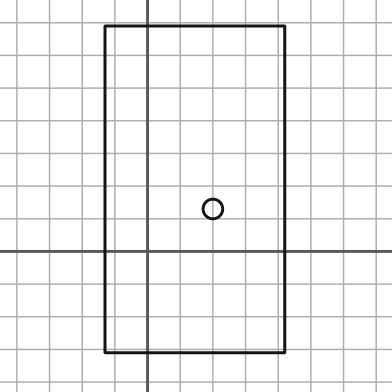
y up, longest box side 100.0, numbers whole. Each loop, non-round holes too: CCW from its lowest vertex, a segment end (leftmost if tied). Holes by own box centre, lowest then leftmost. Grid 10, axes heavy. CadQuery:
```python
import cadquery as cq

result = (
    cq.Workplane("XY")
    .moveTo(-13.0, -31.0)
    .lineTo(42.0, -31.0)
    .lineTo(42.0, 69.0)
    .lineTo(-13.0, 69.0)
    .close()
    .moveTo(20.0, 13.0)
    .circle(3.0)
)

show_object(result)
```